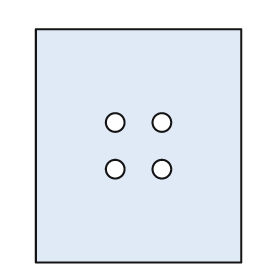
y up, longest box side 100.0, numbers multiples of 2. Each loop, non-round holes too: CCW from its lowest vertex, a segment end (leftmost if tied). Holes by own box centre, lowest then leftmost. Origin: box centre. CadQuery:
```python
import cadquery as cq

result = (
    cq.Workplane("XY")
    .moveTo(-44.0, -50.0)
    .lineTo(44.0, -50.0)
    .lineTo(44.0, 50.0)
    .lineTo(-44.0, 50.0)
    .close()
    .moveTo(-10.0, -10.0)
    .circle(4.0)
    .moveTo(10.0, -10.0)
    .circle(4.0)
    .moveTo(-10.0, 10.0)
    .circle(4.0)
    .moveTo(10.0, 10.0)
    .circle(4.0)
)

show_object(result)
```